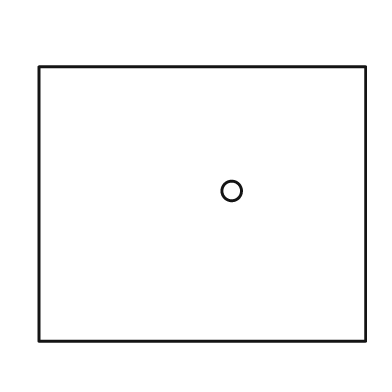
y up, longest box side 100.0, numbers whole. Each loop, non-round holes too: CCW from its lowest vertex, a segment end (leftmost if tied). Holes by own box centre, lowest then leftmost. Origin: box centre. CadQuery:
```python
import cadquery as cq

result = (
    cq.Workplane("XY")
    .moveTo(-50.0, -42.0)
    .lineTo(50.0, -42.0)
    .lineTo(50.0, 42.0)
    .lineTo(-50.0, 42.0)
    .close()
    .moveTo(9.0, 4.0)
    .circle(3.0)
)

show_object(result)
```